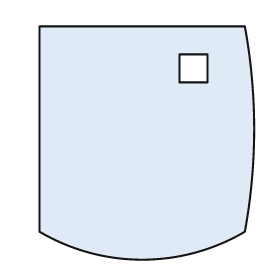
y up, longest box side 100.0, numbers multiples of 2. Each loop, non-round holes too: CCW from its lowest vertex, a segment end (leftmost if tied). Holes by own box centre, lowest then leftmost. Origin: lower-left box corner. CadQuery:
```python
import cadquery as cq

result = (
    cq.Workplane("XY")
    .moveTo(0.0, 12.0)
    .threePointArc((44.0, 0.0), (88.0, 12.0))
    .threePointArc((92.0, 56.0), (88.0, 100.0))
    .lineTo(0.0, 100.0)
    .close()
    .moveTo(60.0, 76.0)
    .lineTo(72.0, 76.0)
    .lineTo(72.0, 88.0)
    .lineTo(60.0, 88.0)
    .close()
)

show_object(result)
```